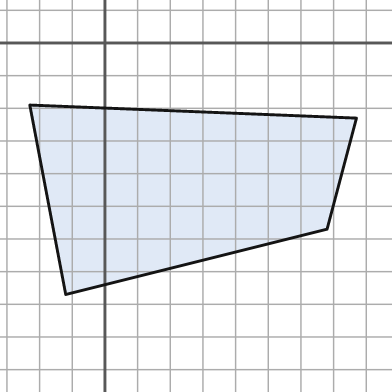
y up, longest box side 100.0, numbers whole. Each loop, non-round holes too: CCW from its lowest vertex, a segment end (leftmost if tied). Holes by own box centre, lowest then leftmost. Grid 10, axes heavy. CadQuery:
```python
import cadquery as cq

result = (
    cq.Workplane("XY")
    .moveTo(-12.0, -77.0)
    .lineTo(68.0, -57.0)
    .lineTo(77.0, -23.0)
    .lineTo(-23.0, -19.0)
    .close()
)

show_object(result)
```